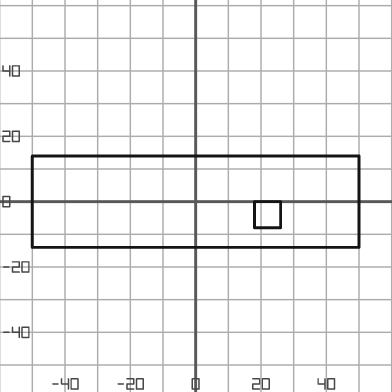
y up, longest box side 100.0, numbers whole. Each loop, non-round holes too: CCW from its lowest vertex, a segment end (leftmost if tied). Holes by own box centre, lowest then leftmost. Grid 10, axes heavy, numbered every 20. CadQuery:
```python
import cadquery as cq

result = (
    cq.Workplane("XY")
    .moveTo(-50.0, -14.0)
    .lineTo(50.0, -14.0)
    .lineTo(50.0, 14.0)
    .lineTo(-50.0, 14.0)
    .close()
    .moveTo(18.0, -8.0)
    .lineTo(26.0, -8.0)
    .lineTo(26.0, 0.0)
    .lineTo(18.0, 0.0)
    .close()
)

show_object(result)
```